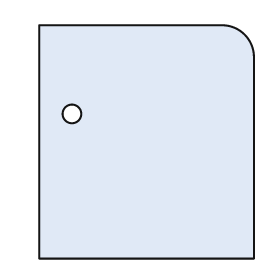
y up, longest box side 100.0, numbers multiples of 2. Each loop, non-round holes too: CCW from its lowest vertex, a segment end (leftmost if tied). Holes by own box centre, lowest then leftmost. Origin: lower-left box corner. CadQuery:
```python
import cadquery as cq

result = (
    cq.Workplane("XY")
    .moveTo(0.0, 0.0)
    .lineTo(92.0, 0.0)
    .lineTo(92.0, 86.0)
    .threePointArc((88.0, 96.0), (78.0, 100.0))
    .lineTo(0.0, 100.0)
    .close()
    .moveTo(14.0, 62.0)
    .circle(4.0)
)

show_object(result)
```